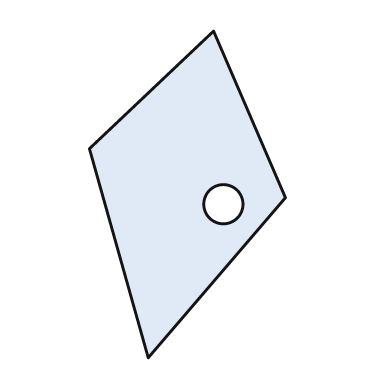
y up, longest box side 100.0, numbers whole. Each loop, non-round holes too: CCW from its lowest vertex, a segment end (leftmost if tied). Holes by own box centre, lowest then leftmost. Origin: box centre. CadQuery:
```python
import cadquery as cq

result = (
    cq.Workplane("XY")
    .moveTo(-12.0, -50.0)
    .lineTo(30.0, -1.0)
    .lineTo(8.0, 50.0)
    .lineTo(-30.0, 14.0)
    .close()
    .moveTo(11.0, -3.0)
    .circle(6.0)
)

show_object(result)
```